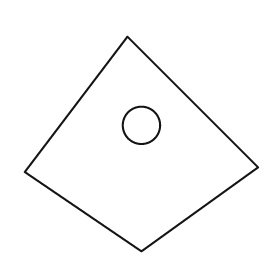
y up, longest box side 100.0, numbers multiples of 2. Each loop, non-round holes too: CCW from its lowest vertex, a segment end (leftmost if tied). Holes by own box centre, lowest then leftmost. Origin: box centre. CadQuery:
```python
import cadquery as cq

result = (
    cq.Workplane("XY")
    .moveTo(0.0, -46.0)
    .lineTo(50.0, -10.0)
    .lineTo(-6.0, 46.0)
    .lineTo(-50.0, -12.0)
    .close()
    .moveTo(0.0, 8.0)
    .circle(8.0)
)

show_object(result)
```